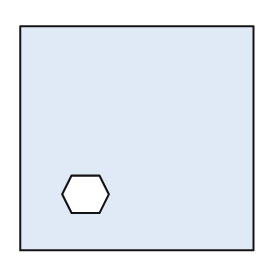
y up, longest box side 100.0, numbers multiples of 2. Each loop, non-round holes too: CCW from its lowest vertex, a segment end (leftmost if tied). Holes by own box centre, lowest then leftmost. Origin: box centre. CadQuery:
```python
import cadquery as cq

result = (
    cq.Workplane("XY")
    .moveTo(-50.0, -48.0)
    .lineTo(50.0, -48.0)
    .lineTo(50.0, 48.0)
    .lineTo(-50.0, 48.0)
    .close()
    .moveTo(-28.0, -32.0)
    .lineTo(-16.0, -32.0)
    .lineTo(-12.0, -24.0)
    .lineTo(-16.0, -16.0)
    .lineTo(-28.0, -16.0)
    .lineTo(-32.0, -24.0)
    .close()
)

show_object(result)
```